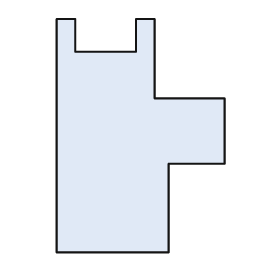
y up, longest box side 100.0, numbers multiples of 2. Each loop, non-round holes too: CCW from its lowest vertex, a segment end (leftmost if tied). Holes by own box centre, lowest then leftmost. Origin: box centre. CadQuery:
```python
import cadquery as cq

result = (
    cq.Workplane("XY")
    .moveTo(-36.0, -50.0)
    .lineTo(12.0, -50.0)
    .lineTo(12.0, -12.0)
    .lineTo(36.0, -12.0)
    .lineTo(36.0, 16.0)
    .lineTo(6.0, 16.0)
    .lineTo(6.0, 50.0)
    .lineTo(-2.0, 50.0)
    .lineTo(-2.0, 36.0)
    .lineTo(-28.0, 36.0)
    .lineTo(-28.0, 50.0)
    .lineTo(-36.0, 50.0)
    .close()
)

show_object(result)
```